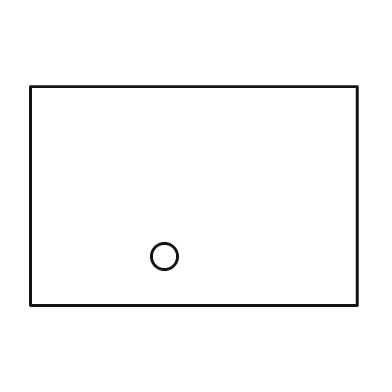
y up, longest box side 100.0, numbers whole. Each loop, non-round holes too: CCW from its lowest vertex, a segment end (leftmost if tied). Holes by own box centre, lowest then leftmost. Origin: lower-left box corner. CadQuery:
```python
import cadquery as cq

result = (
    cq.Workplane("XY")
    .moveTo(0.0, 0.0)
    .lineTo(100.0, 0.0)
    .lineTo(100.0, 67.0)
    .lineTo(0.0, 67.0)
    .close()
    .moveTo(41.0, 15.0)
    .circle(4.0)
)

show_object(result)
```